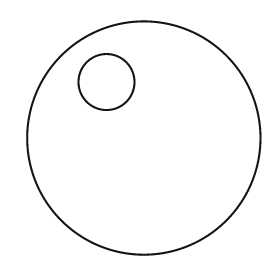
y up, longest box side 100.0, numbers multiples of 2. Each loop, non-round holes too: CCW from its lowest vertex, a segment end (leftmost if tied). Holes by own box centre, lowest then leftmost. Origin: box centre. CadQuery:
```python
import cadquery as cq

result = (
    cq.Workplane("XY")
    .moveTo(0.0, 0.0)
    .circle(50.0)
    .moveTo(-16.0, 24.0)
    .circle(12.0)
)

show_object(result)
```